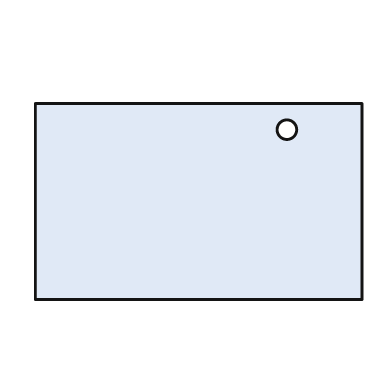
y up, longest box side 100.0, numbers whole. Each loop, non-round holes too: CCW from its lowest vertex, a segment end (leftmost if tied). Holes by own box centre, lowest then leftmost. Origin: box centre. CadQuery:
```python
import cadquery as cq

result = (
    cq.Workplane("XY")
    .moveTo(-50.0, -30.0)
    .lineTo(50.0, -30.0)
    .lineTo(50.0, 30.0)
    .lineTo(-50.0, 30.0)
    .close()
    .moveTo(27.0, 22.0)
    .circle(3.0)
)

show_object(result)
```